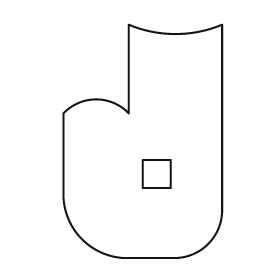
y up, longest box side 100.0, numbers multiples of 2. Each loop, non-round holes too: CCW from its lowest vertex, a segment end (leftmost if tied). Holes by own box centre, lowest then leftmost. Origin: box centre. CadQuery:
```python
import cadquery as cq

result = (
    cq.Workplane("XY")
    .moveTo(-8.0, -50.0)
    .lineTo(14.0, -50.0)
    .threePointArc((28.0, -44.0), (34.0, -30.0))
    .lineTo(34.0, 50.0)
    .threePointArc((14.0, 46.0), (-6.0, 50.0))
    .lineTo(-6.0, 12.0)
    .threePointArc((-20.0, 18.0), (-34.0, 12.0))
    .lineTo(-34.0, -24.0)
    .threePointArc((-26.0, -42.0), (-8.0, -50.0))
    .close()
    .moveTo(0.0, -20.0)
    .lineTo(12.0, -20.0)
    .lineTo(12.0, -8.0)
    .lineTo(0.0, -8.0)
    .close()
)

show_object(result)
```